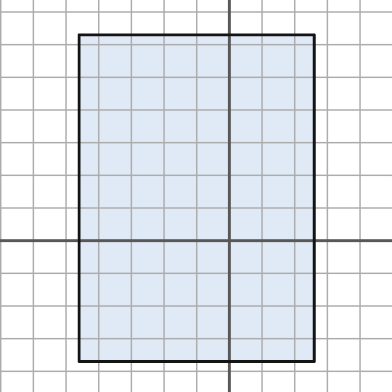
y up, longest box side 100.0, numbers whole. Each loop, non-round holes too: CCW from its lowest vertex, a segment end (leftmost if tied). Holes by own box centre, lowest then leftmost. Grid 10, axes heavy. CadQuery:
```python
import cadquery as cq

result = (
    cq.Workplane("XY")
    .moveTo(-46.0, -37.0)
    .lineTo(26.0, -37.0)
    .lineTo(26.0, 63.0)
    .lineTo(-46.0, 63.0)
    .close()
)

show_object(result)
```